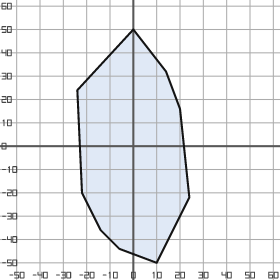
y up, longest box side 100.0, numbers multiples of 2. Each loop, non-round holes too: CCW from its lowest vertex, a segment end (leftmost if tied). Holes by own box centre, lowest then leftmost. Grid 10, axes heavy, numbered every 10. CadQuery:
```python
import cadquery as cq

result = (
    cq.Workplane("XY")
    .moveTo(10.0, -50.0)
    .lineTo(24.0, -22.0)
    .lineTo(20.0, 16.0)
    .lineTo(14.0, 32.0)
    .lineTo(0.0, 50.0)
    .lineTo(-24.0, 24.0)
    .lineTo(-22.0, -20.0)
    .lineTo(-14.0, -36.0)
    .lineTo(-6.0, -44.0)
    .close()
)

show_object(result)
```